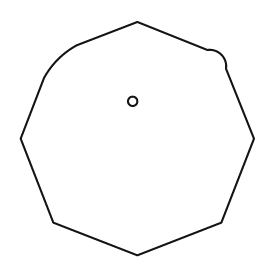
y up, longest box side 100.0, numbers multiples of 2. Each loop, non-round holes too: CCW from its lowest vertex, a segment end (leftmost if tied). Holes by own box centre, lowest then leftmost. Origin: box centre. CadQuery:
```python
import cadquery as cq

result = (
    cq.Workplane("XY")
    .moveTo(0.0, -50.0)
    .lineTo(36.0, -36.0)
    .lineTo(50.0, 0.0)
    .lineTo(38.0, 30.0)
    .threePointArc((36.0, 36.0), (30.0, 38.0))
    .lineTo(0.0, 50.0)
    .lineTo(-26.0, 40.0)
    .threePointArc((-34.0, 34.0), (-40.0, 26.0))
    .lineTo(-50.0, 0.0)
    .lineTo(-36.0, -36.0)
    .close()
    .moveTo(-2.0, 16.0)
    .circle(2.0)
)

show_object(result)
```